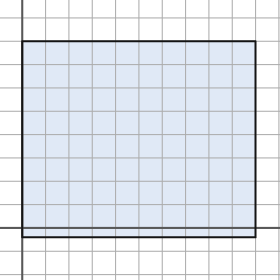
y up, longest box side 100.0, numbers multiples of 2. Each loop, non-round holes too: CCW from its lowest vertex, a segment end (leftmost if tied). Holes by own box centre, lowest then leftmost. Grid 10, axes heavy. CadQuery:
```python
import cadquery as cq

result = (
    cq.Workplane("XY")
    .moveTo(0.0, -4.0)
    .lineTo(100.0, -4.0)
    .lineTo(100.0, 80.0)
    .lineTo(0.0, 80.0)
    .close()
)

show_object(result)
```